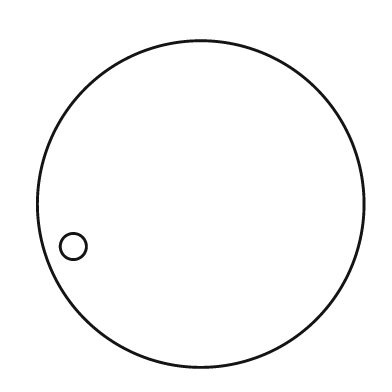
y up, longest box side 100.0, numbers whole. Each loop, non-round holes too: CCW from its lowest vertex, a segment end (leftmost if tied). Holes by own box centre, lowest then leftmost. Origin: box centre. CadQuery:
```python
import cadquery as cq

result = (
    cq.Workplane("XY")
    .moveTo(0.0, 0.0)
    .circle(50.0)
    .moveTo(-39.0, -13.0)
    .circle(4.0)
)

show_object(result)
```